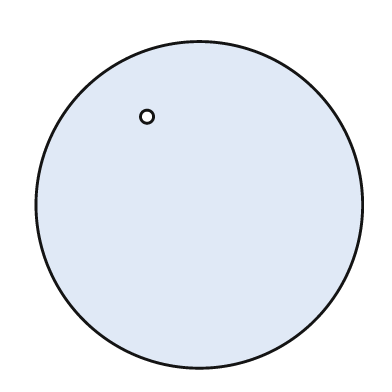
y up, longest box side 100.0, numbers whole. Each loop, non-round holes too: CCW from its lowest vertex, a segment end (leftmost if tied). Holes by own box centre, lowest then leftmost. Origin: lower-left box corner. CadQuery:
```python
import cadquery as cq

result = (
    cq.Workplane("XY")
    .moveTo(50.0, 50.0)
    .circle(50.0)
    .moveTo(34.0, 77.0)
    .circle(2.0)
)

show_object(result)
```